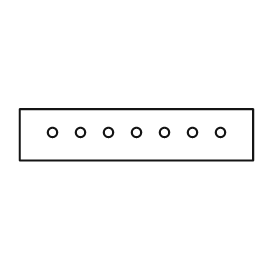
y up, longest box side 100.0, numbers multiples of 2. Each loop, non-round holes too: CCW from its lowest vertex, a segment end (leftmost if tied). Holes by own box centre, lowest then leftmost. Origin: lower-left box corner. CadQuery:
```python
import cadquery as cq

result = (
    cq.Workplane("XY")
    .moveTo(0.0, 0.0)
    .lineTo(100.0, 0.0)
    .lineTo(100.0, 22.0)
    .lineTo(0.0, 22.0)
    .close()
    .moveTo(14.0, 12.0)
    .circle(2.0)
    .moveTo(26.0, 12.0)
    .circle(2.0)
    .moveTo(38.0, 12.0)
    .circle(2.0)
    .moveTo(50.0, 12.0)
    .circle(2.0)
    .moveTo(62.0, 12.0)
    .circle(2.0)
    .moveTo(74.0, 12.0)
    .circle(2.0)
    .moveTo(86.0, 12.0)
    .circle(2.0)
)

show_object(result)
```